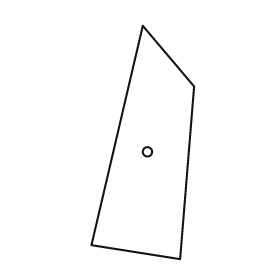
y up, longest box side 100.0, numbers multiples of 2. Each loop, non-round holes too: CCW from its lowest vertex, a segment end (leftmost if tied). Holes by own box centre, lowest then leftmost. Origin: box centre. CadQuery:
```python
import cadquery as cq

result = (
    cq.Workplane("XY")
    .moveTo(16.0, -50.0)
    .lineTo(22.0, 24.0)
    .lineTo(0.0, 50.0)
    .lineTo(-22.0, -44.0)
    .close()
    .moveTo(2.0, -4.0)
    .circle(2.0)
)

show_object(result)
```